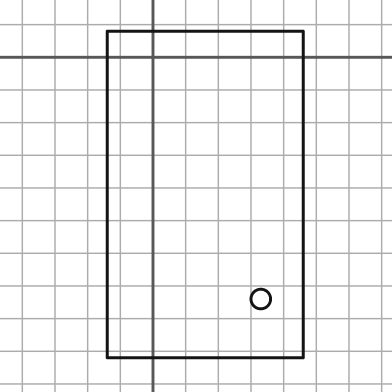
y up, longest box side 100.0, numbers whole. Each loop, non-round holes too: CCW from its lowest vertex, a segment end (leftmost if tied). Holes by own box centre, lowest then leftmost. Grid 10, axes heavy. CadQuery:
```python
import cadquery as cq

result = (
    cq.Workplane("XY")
    .moveTo(-14.0, -92.0)
    .lineTo(46.0, -92.0)
    .lineTo(46.0, 8.0)
    .lineTo(-14.0, 8.0)
    .close()
    .moveTo(33.0, -74.0)
    .circle(3.0)
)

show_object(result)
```